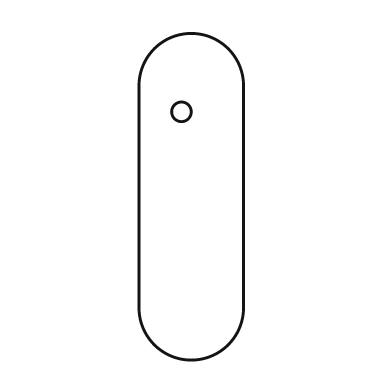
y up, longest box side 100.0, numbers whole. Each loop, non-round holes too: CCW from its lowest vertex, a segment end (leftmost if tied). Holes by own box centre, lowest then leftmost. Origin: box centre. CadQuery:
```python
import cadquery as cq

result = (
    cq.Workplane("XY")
    .moveTo(-16.0, -34.0)
    .threePointArc((0.0, -50.0), (16.0, -34.0))
    .lineTo(16.0, 34.0)
    .threePointArc((0.0, 50.0), (-16.0, 34.0))
    .close()
    .moveTo(-3.0, 26.0)
    .circle(3.0)
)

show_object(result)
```